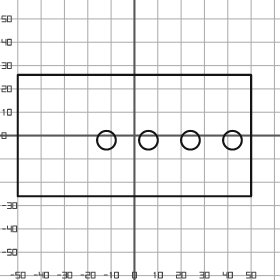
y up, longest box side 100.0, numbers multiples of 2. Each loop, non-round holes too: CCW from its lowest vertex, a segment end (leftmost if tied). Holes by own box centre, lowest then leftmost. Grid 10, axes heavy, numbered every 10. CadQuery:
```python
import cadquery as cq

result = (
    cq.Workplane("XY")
    .moveTo(-50.0, -26.0)
    .lineTo(50.0, -26.0)
    .lineTo(50.0, 26.0)
    .lineTo(-50.0, 26.0)
    .close()
    .moveTo(-12.0, -2.0)
    .circle(4.0)
    .moveTo(6.0, -2.0)
    .circle(4.0)
    .moveTo(24.0, -2.0)
    .circle(4.0)
    .moveTo(42.0, -2.0)
    .circle(4.0)
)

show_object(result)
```